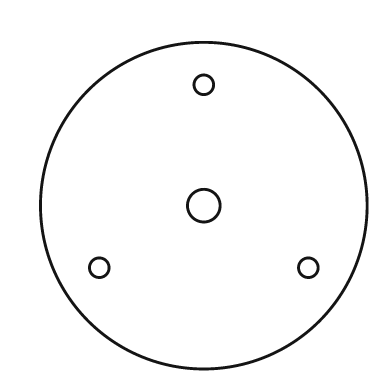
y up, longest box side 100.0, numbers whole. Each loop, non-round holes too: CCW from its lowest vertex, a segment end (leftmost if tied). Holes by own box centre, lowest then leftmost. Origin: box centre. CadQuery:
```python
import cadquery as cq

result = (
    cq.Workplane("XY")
    .moveTo(0.0, 0.0)
    .circle(50.0)
    .moveTo(-32.0, -19.0)
    .circle(3.0)
    .moveTo(32.0, -19.0)
    .circle(3.0)
    .moveTo(0.0, 0.0)
    .circle(5.0)
    .moveTo(0.0, 37.0)
    .circle(3.0)
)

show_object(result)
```